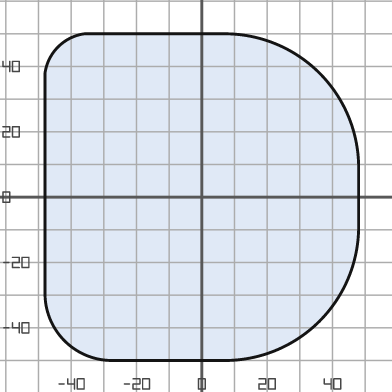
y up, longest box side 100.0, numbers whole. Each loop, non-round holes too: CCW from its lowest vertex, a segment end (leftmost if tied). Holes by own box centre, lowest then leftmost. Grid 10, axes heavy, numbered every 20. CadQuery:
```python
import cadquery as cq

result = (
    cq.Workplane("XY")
    .moveTo(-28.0, -50.0)
    .lineTo(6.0, -50.0)
    .threePointArc((36.0, -38.0), (48.0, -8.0))
    .lineTo(48.0, 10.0)
    .threePointArc((36.0, 38.0), (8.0, 50.0))
    .lineTo(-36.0, 50.0)
    .threePointArc((-44.0, 46.0), (-48.0, 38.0))
    .lineTo(-48.0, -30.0)
    .threePointArc((-42.0, -44.0), (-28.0, -50.0))
    .close()
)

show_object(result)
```